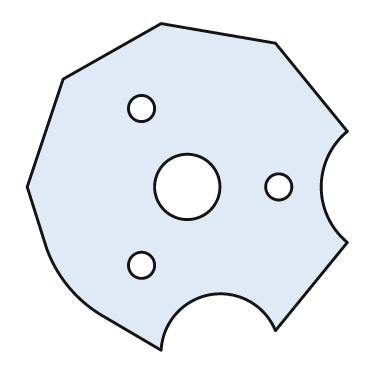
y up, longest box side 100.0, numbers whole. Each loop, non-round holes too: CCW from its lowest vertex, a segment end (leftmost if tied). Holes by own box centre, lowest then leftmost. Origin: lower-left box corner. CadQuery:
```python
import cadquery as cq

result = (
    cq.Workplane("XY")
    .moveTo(41.0, 0.0)
    .threePointArc((56.0, 17.0), (76.0, 6.0))
    .lineTo(98.0, 33.0)
    .threePointArc((90.0, 50.0), (98.0, 67.0))
    .lineTo(76.0, 94.0)
    .lineTo(41.0, 100.0)
    .lineTo(11.0, 83.0)
    .lineTo(0.0, 50.0)
    .lineTo(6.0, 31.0)
    .threePointArc((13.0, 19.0), (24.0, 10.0))
    .close()
    .moveTo(35.0, 26.0)
    .circle(4.0)
    .moveTo(49.0, 50.0)
    .circle(10.0)
    .moveTo(77.0, 50.0)
    .circle(4.0)
    .moveTo(35.0, 74.0)
    .circle(4.0)
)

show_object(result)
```